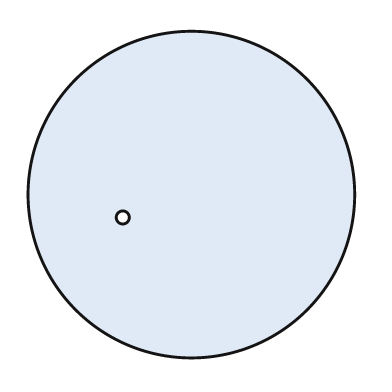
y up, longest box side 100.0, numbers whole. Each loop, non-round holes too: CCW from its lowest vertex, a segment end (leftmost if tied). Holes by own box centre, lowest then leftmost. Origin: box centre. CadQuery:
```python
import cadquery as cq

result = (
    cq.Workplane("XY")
    .moveTo(0.0, 0.0)
    .circle(50.0)
    .moveTo(-21.0, -7.0)
    .circle(2.0)
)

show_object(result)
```